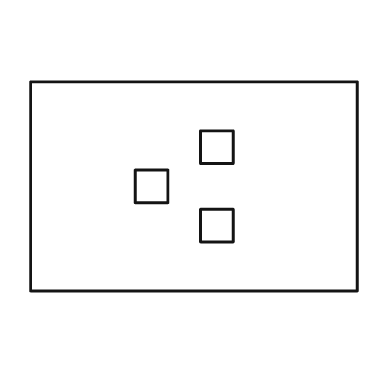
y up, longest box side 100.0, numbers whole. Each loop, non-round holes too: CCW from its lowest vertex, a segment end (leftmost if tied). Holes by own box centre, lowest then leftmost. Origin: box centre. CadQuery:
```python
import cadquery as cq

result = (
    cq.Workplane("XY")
    .moveTo(-50.0, -32.0)
    .lineTo(50.0, -32.0)
    .lineTo(50.0, 32.0)
    .lineTo(-50.0, 32.0)
    .close()
    .moveTo(2.0, -17.0)
    .lineTo(12.0, -17.0)
    .lineTo(12.0, -7.0)
    .lineTo(2.0, -7.0)
    .close()
    .moveTo(-18.0, -5.0)
    .lineTo(-8.0, -5.0)
    .lineTo(-8.0, 5.0)
    .lineTo(-18.0, 5.0)
    .close()
    .moveTo(2.0, 7.0)
    .lineTo(12.0, 7.0)
    .lineTo(12.0, 17.0)
    .lineTo(2.0, 17.0)
    .close()
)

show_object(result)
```